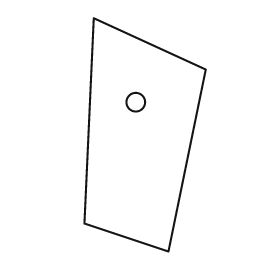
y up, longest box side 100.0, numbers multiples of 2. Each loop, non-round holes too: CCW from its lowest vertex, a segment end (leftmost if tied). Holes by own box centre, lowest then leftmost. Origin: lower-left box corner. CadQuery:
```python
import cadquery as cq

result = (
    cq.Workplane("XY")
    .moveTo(36.0, 0.0)
    .lineTo(52.0, 78.0)
    .lineTo(4.0, 100.0)
    .lineTo(0.0, 12.0)
    .close()
    .moveTo(22.0, 64.0)
    .circle(4.0)
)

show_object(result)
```